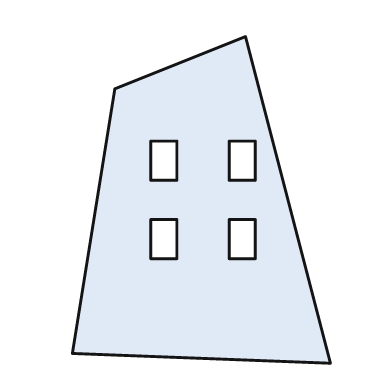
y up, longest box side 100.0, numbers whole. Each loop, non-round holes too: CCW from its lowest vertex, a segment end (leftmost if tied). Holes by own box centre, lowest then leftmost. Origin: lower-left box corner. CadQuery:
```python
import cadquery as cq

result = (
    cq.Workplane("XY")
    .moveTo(79.0, 0.0)
    .lineTo(53.0, 100.0)
    .lineTo(13.0, 84.0)
    .lineTo(0.0, 3.0)
    .close()
    .moveTo(24.0, 32.0)
    .lineTo(32.0, 32.0)
    .lineTo(32.0, 44.0)
    .lineTo(24.0, 44.0)
    .close()
    .moveTo(48.0, 32.0)
    .lineTo(56.0, 32.0)
    .lineTo(56.0, 44.0)
    .lineTo(48.0, 44.0)
    .close()
    .moveTo(24.0, 56.0)
    .lineTo(32.0, 56.0)
    .lineTo(32.0, 68.0)
    .lineTo(24.0, 68.0)
    .close()
    .moveTo(48.0, 56.0)
    .lineTo(56.0, 56.0)
    .lineTo(56.0, 68.0)
    .lineTo(48.0, 68.0)
    .close()
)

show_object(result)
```